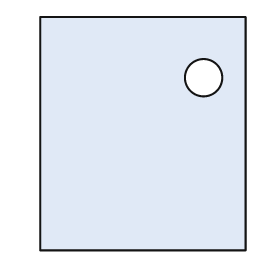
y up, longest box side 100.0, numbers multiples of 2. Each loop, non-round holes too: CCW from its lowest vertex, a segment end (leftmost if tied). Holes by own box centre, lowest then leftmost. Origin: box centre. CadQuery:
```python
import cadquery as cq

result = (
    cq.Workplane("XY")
    .moveTo(-44.0, -50.0)
    .lineTo(44.0, -50.0)
    .lineTo(44.0, 50.0)
    .lineTo(-44.0, 50.0)
    .close()
    .moveTo(26.0, 24.0)
    .circle(8.0)
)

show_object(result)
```